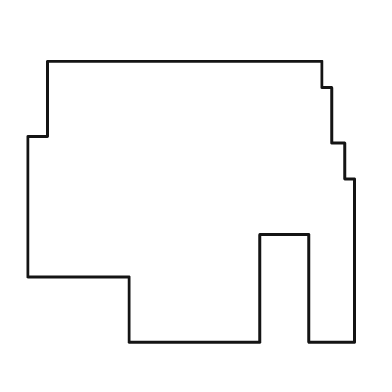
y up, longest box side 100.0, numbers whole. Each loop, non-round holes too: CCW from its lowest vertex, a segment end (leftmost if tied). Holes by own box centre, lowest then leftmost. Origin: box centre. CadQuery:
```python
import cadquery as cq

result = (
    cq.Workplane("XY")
    .moveTo(-19.0, -43.0)
    .lineTo(21.0, -43.0)
    .lineTo(21.0, -10.0)
    .lineTo(36.0, -10.0)
    .lineTo(36.0, -43.0)
    .lineTo(50.0, -43.0)
    .lineTo(50.0, 7.0)
    .lineTo(47.0, 7.0)
    .lineTo(47.0, 18.0)
    .lineTo(43.0, 18.0)
    .lineTo(43.0, 35.0)
    .lineTo(40.0, 35.0)
    .lineTo(40.0, 43.0)
    .lineTo(-44.0, 43.0)
    .lineTo(-44.0, 20.0)
    .lineTo(-50.0, 20.0)
    .lineTo(-50.0, -23.0)
    .lineTo(-19.0, -23.0)
    .close()
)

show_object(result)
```